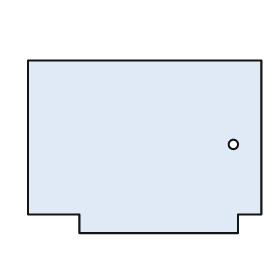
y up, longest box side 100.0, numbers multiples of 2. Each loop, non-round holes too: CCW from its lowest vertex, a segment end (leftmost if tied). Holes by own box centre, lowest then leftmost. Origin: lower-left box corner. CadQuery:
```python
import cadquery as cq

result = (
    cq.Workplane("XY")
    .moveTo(22.0, 0.0)
    .lineTo(90.0, 0.0)
    .lineTo(90.0, 8.0)
    .lineTo(100.0, 8.0)
    .lineTo(100.0, 74.0)
    .lineTo(0.0, 74.0)
    .lineTo(0.0, 8.0)
    .lineTo(22.0, 8.0)
    .close()
    .moveTo(88.0, 38.0)
    .circle(2.0)
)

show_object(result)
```